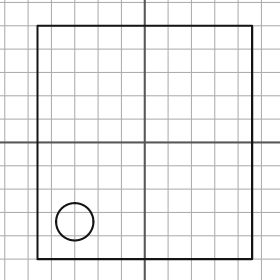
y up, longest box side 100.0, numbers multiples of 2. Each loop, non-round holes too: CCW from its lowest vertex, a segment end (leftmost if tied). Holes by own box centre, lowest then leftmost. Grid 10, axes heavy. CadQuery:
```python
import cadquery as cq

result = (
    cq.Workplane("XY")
    .moveTo(-46.0, -50.0)
    .lineTo(46.0, -50.0)
    .lineTo(46.0, 50.0)
    .lineTo(-46.0, 50.0)
    .close()
    .moveTo(-30.0, -34.0)
    .circle(8.0)
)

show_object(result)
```